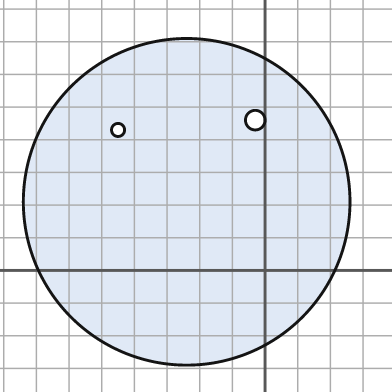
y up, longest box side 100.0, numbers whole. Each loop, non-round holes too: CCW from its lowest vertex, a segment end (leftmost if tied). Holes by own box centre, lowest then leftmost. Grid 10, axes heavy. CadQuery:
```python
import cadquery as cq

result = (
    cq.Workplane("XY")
    .moveTo(-24.0, 21.0)
    .circle(50.0)
    .moveTo(-45.0, 43.0)
    .circle(2.0)
    .moveTo(-3.0, 46.0)
    .circle(3.0)
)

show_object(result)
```